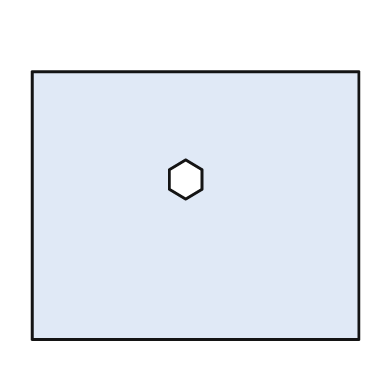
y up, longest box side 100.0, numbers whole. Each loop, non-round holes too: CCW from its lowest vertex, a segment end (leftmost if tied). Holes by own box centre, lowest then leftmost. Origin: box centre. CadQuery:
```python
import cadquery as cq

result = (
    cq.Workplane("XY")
    .moveTo(-50.0, -41.0)
    .lineTo(50.0, -41.0)
    .lineTo(50.0, 41.0)
    .lineTo(-50.0, 41.0)
    .close()
    .moveTo(-3.0, 2.0)
    .lineTo(2.0, 5.0)
    .lineTo(2.0, 11.0)
    .lineTo(-3.0, 14.0)
    .lineTo(-8.0, 11.0)
    .lineTo(-8.0, 5.0)
    .close()
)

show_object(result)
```